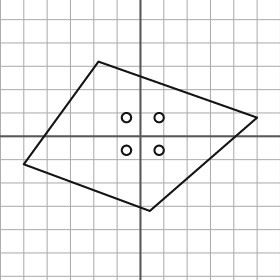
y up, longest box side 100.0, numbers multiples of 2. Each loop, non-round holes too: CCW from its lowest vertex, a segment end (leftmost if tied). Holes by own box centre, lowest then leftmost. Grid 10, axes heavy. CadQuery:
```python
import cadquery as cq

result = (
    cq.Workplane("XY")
    .moveTo(4.0, -32.0)
    .lineTo(50.0, 8.0)
    .lineTo(-18.0, 32.0)
    .lineTo(-50.0, -12.0)
    .close()
    .moveTo(-6.0, -6.0)
    .circle(2.0)
    .moveTo(8.0, -6.0)
    .circle(2.0)
    .moveTo(-6.0, 8.0)
    .circle(2.0)
    .moveTo(8.0, 8.0)
    .circle(2.0)
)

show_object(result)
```